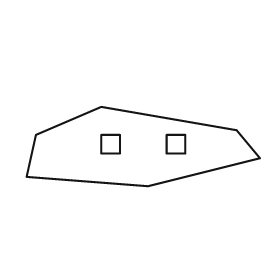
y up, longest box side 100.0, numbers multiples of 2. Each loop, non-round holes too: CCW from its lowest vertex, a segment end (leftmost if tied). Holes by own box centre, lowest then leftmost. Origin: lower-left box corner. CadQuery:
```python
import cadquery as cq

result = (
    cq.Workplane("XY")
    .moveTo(52.0, 0.0)
    .lineTo(100.0, 12.0)
    .lineTo(90.0, 24.0)
    .lineTo(32.0, 34.0)
    .lineTo(4.0, 22.0)
    .lineTo(0.0, 4.0)
    .close()
    .moveTo(32.0, 14.0)
    .lineTo(40.0, 14.0)
    .lineTo(40.0, 22.0)
    .lineTo(32.0, 22.0)
    .close()
    .moveTo(60.0, 14.0)
    .lineTo(68.0, 14.0)
    .lineTo(68.0, 22.0)
    .lineTo(60.0, 22.0)
    .close()
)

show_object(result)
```